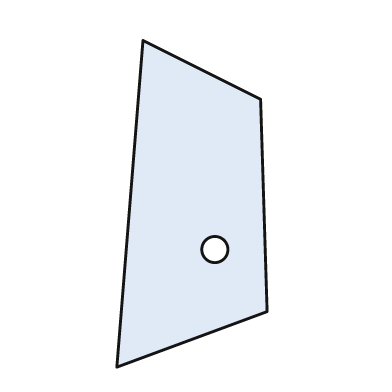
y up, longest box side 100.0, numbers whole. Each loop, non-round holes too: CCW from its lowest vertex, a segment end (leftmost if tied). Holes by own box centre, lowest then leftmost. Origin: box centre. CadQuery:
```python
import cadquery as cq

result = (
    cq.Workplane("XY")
    .moveTo(-23.0, -50.0)
    .lineTo(23.0, -33.0)
    .lineTo(21.0, 32.0)
    .lineTo(-15.0, 50.0)
    .close()
    .moveTo(7.0, -14.0)
    .circle(4.0)
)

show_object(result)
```